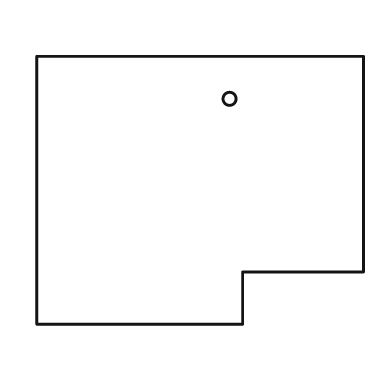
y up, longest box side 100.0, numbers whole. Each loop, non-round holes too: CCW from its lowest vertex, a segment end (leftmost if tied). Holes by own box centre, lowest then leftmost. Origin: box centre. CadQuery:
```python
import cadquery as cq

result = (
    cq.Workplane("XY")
    .moveTo(-50.0, -41.0)
    .lineTo(13.0, -41.0)
    .lineTo(13.0, -25.0)
    .lineTo(50.0, -25.0)
    .lineTo(50.0, 41.0)
    .lineTo(-50.0, 41.0)
    .close()
    .moveTo(9.0, 28.0)
    .circle(2.0)
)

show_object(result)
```